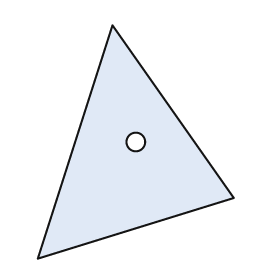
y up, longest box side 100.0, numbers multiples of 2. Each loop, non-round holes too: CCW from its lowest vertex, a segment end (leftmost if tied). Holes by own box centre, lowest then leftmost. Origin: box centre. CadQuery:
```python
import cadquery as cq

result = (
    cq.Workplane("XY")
    .moveTo(-42.0, -50.0)
    .lineTo(42.0, -24.0)
    .lineTo(-10.0, 50.0)
    .close()
    .moveTo(0.0, 0.0)
    .circle(4.0)
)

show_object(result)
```